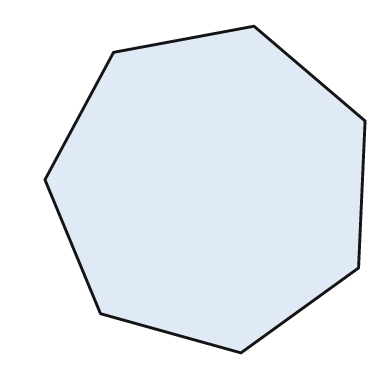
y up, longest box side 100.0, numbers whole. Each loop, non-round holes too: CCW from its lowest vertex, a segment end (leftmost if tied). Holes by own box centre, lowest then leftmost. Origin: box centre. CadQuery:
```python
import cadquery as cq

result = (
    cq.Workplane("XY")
    .moveTo(11.0, -50.0)
    .lineTo(47.0, -24.0)
    .lineTo(49.0, 21.0)
    .lineTo(15.0, 50.0)
    .lineTo(-28.0, 42.0)
    .lineTo(-49.0, 3.0)
    .lineTo(-32.0, -38.0)
    .close()
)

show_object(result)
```